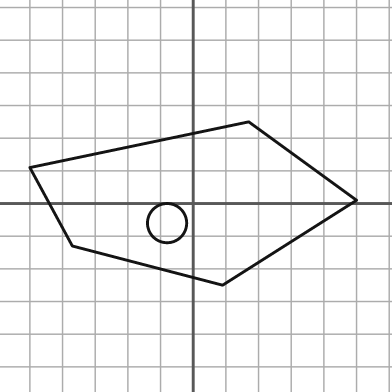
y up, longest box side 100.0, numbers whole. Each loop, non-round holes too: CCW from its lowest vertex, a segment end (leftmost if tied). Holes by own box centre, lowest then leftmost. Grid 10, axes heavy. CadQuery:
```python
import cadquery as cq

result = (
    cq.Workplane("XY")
    .moveTo(9.0, -25.0)
    .lineTo(50.0, 1.0)
    .lineTo(17.0, 25.0)
    .lineTo(-50.0, 11.0)
    .lineTo(-37.0, -13.0)
    .close()
    .moveTo(-8.0, -6.0)
    .circle(6.0)
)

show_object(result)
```